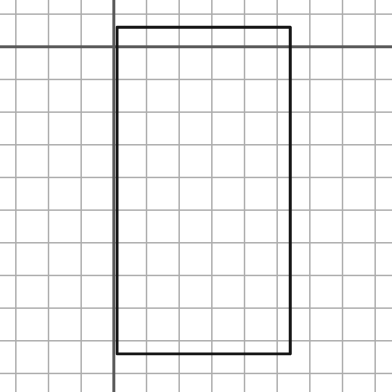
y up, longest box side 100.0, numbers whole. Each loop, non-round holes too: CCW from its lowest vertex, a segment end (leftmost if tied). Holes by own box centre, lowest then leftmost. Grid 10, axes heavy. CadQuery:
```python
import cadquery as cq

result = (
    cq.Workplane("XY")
    .moveTo(1.0, -94.0)
    .lineTo(54.0, -94.0)
    .lineTo(54.0, 6.0)
    .lineTo(1.0, 6.0)
    .close()
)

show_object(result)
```